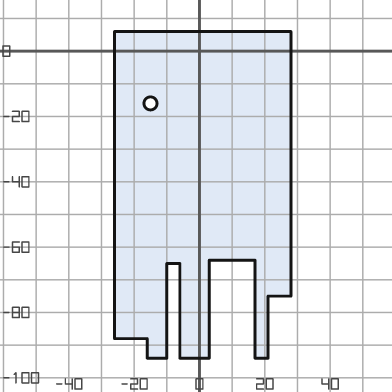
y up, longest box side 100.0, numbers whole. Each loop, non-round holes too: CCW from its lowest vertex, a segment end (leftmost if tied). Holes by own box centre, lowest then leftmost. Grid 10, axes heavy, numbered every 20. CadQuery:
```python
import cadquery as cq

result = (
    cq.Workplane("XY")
    .moveTo(-16.0, -94.0)
    .lineTo(-10.0, -94.0)
    .lineTo(-10.0, -65.0)
    .lineTo(-6.0, -65.0)
    .lineTo(-6.0, -94.0)
    .lineTo(3.0, -94.0)
    .lineTo(3.0, -64.0)
    .lineTo(17.0, -64.0)
    .lineTo(17.0, -94.0)
    .lineTo(21.0, -94.0)
    .lineTo(21.0, -75.0)
    .lineTo(28.0, -75.0)
    .lineTo(28.0, 6.0)
    .lineTo(-26.0, 6.0)
    .lineTo(-26.0, -88.0)
    .lineTo(-16.0, -88.0)
    .close()
    .moveTo(-15.0, -16.0)
    .circle(2.0)
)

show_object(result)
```